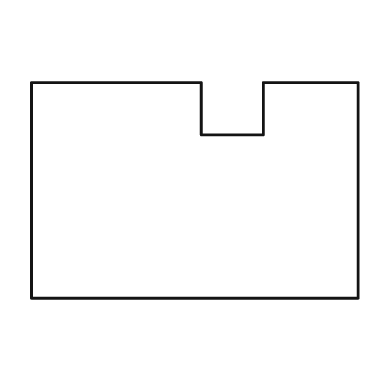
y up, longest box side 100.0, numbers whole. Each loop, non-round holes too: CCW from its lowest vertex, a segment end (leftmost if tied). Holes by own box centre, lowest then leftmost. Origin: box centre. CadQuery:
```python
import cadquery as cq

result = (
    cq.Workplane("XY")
    .moveTo(-50.0, -33.0)
    .lineTo(50.0, -33.0)
    .lineTo(50.0, 33.0)
    .lineTo(21.0, 33.0)
    .lineTo(21.0, 17.0)
    .lineTo(2.0, 17.0)
    .lineTo(2.0, 33.0)
    .lineTo(-50.0, 33.0)
    .close()
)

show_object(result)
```